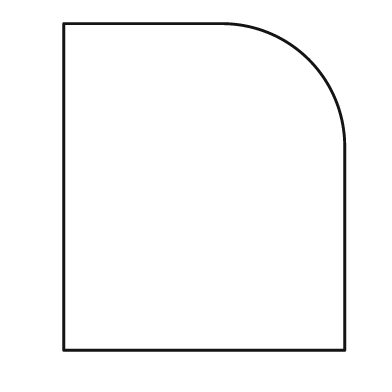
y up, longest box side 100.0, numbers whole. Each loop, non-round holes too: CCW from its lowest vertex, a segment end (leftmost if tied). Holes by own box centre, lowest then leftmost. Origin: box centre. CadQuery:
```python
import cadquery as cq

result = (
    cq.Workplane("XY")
    .moveTo(-43.0, -50.0)
    .lineTo(43.0, -50.0)
    .lineTo(43.0, 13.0)
    .threePointArc((32.0, 39.0), (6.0, 50.0))
    .lineTo(-43.0, 50.0)
    .close()
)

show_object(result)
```